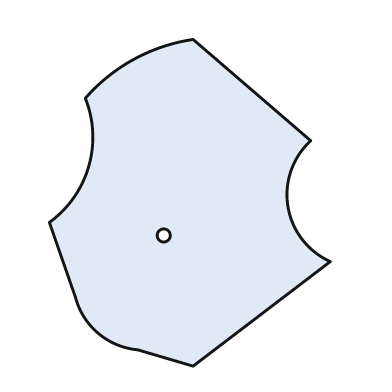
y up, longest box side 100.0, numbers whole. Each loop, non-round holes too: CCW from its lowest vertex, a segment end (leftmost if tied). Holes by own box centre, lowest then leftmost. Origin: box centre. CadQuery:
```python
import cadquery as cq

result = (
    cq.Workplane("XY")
    .moveTo(1.0, -50.0)
    .lineTo(43.0, -18.0)
    .threePointArc((30.0, -1.0), (37.0, 19.0))
    .lineTo(1.0, 50.0)
    .threePointArc((-17.0, 44.0), (-32.0, 32.0))
    .threePointArc((-31.0, 11.0), (-43.0, -6.0))
    .lineTo(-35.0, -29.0)
    .threePointArc((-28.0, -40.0), (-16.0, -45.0))
    .close()
    .moveTo(-8.0, -10.0)
    .circle(2.0)
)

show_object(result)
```